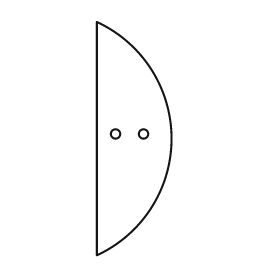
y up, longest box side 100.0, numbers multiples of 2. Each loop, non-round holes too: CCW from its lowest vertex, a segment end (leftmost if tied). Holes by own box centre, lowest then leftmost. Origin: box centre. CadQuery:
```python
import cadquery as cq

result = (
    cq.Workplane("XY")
    .moveTo(-16.0, -50.0)
    .threePointArc((16.0, 0.0), (-16.0, 50.0))
    .close()
    .moveTo(-8.0, 2.0)
    .circle(2.0)
    .moveTo(4.0, 2.0)
    .circle(2.0)
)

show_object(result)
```